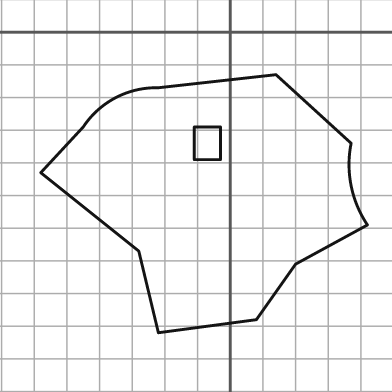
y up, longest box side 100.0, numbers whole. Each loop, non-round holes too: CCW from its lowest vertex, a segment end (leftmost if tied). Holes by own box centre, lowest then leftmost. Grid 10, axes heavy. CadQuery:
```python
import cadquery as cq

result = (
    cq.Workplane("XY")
    .moveTo(-22.0, -92.0)
    .lineTo(8.0, -88.0)
    .lineTo(20.0, -71.0)
    .lineTo(42.0, -59.0)
    .threePointArc((37.0, -47.0), (37.0, -34.0))
    .lineTo(14.0, -13.0)
    .lineTo(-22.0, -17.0)
    .threePointArc((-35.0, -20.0), (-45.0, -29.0))
    .lineTo(-58.0, -43.0)
    .lineTo(-28.0, -67.0)
    .close()
    .moveTo(-11.0, -39.0)
    .lineTo(-3.0, -39.0)
    .lineTo(-3.0, -29.0)
    .lineTo(-11.0, -29.0)
    .close()
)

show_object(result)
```